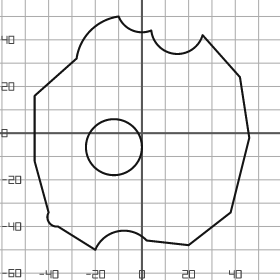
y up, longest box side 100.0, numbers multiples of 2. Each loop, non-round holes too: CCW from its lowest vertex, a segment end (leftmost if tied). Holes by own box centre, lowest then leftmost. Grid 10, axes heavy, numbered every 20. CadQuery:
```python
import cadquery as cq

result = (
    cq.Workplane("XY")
    .moveTo(-20.0, -50.0)
    .threePointArc((-10.0, -42.0), (2.0, -46.0))
    .lineTo(20.0, -48.0)
    .lineTo(38.0, -34.0)
    .lineTo(46.0, -2.0)
    .lineTo(42.0, 24.0)
    .lineTo(26.0, 42.0)
    .threePointArc((14.0, 34.0), (4.0, 44.0))
    .threePointArc((-4.0, 44.0), (-10.0, 50.0))
    .threePointArc((-22.0, 44.0), (-28.0, 32.0))
    .lineTo(-46.0, 16.0)
    .lineTo(-46.0, -12.0)
    .lineTo(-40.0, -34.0)
    .threePointArc((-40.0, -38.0), (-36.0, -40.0))
    .close()
    .moveTo(-12.0, -6.0)
    .circle(12.0)
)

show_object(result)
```